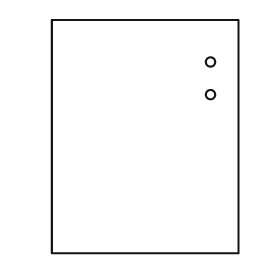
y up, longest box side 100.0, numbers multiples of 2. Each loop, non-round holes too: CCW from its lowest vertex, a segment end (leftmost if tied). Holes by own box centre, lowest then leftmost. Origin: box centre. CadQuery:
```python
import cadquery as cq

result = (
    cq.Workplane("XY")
    .moveTo(-40.0, -50.0)
    .lineTo(40.0, -50.0)
    .lineTo(40.0, 50.0)
    .lineTo(-40.0, 50.0)
    .close()
    .moveTo(28.0, 18.0)
    .circle(2.0)
    .moveTo(28.0, 32.0)
    .circle(2.0)
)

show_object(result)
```